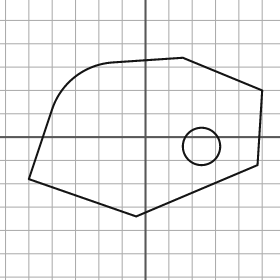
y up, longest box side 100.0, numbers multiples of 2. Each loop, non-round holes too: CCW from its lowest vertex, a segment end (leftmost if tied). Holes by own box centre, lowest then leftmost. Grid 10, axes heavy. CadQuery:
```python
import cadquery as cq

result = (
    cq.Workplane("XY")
    .moveTo(-4.0, -34.0)
    .lineTo(48.0, -12.0)
    .lineTo(50.0, 20.0)
    .lineTo(16.0, 34.0)
    .lineTo(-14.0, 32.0)
    .threePointArc((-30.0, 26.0), (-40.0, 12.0))
    .lineTo(-50.0, -18.0)
    .close()
    .moveTo(24.0, -4.0)
    .circle(8.0)
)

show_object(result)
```